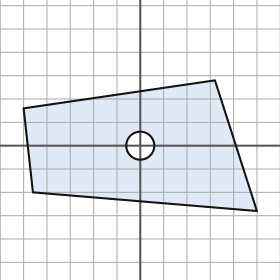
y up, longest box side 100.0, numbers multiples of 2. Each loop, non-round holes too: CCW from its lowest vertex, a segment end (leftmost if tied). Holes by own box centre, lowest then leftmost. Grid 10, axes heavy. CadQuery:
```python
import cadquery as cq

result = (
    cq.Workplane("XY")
    .moveTo(50.0, -28.0)
    .lineTo(32.0, 28.0)
    .lineTo(-50.0, 16.0)
    .lineTo(-46.0, -20.0)
    .close()
    .moveTo(0.0, 0.0)
    .circle(6.0)
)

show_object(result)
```